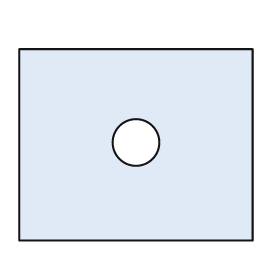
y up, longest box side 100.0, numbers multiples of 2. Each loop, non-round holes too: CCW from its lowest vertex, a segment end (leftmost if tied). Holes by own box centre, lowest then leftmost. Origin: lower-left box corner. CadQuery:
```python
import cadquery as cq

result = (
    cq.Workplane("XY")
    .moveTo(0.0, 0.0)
    .lineTo(100.0, 0.0)
    .lineTo(100.0, 82.0)
    .lineTo(0.0, 82.0)
    .close()
    .moveTo(50.0, 42.0)
    .circle(10.0)
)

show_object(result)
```